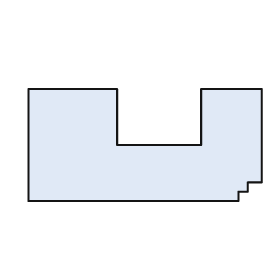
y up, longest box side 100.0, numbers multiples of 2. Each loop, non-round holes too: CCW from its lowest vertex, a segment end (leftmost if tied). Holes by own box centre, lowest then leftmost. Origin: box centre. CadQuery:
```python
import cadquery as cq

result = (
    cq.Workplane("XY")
    .moveTo(-50.0, -24.0)
    .lineTo(40.0, -24.0)
    .lineTo(40.0, -20.0)
    .lineTo(44.0, -20.0)
    .lineTo(44.0, -16.0)
    .lineTo(50.0, -16.0)
    .lineTo(50.0, 24.0)
    .lineTo(24.0, 24.0)
    .lineTo(24.0, 0.0)
    .lineTo(-12.0, 0.0)
    .lineTo(-12.0, 24.0)
    .lineTo(-50.0, 24.0)
    .close()
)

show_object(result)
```